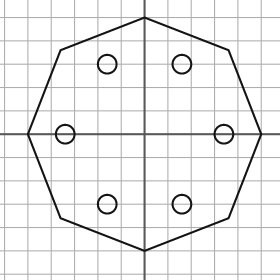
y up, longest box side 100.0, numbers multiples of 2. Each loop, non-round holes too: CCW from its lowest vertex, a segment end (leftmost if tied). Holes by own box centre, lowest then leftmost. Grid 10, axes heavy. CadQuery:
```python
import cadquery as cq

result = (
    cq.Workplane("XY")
    .moveTo(0.0, -50.0)
    .lineTo(36.0, -36.0)
    .lineTo(50.0, 0.0)
    .lineTo(36.0, 36.0)
    .lineTo(0.0, 50.0)
    .lineTo(-36.0, 36.0)
    .lineTo(-50.0, 0.0)
    .lineTo(-36.0, -36.0)
    .close()
    .moveTo(-16.0, -30.0)
    .circle(4.0)
    .moveTo(16.0, -30.0)
    .circle(4.0)
    .moveTo(-34.0, 0.0)
    .circle(4.0)
    .moveTo(34.0, 0.0)
    .circle(4.0)
    .moveTo(-16.0, 30.0)
    .circle(4.0)
    .moveTo(16.0, 30.0)
    .circle(4.0)
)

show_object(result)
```